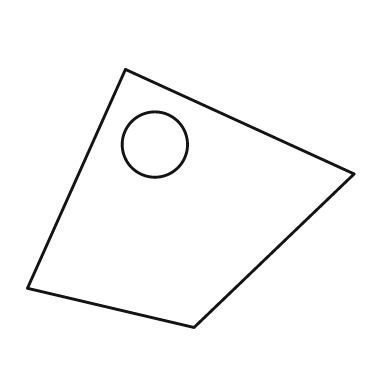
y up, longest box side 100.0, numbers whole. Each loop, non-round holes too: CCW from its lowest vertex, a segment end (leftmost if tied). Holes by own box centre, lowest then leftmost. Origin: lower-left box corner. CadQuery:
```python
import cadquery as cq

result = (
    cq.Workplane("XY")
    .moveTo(51.0, 0.0)
    .lineTo(100.0, 47.0)
    .lineTo(30.0, 79.0)
    .lineTo(0.0, 12.0)
    .close()
    .moveTo(39.0, 56.0)
    .circle(10.0)
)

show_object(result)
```